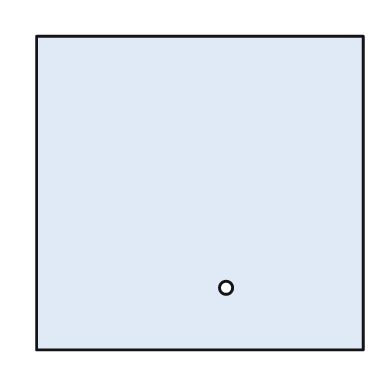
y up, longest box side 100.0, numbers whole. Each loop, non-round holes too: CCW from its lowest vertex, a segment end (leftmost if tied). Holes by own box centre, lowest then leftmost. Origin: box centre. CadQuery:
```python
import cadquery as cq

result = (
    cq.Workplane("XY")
    .moveTo(-50.0, -48.0)
    .lineTo(50.0, -48.0)
    .lineTo(50.0, 48.0)
    .lineTo(-50.0, 48.0)
    .close()
    .moveTo(8.0, -29.0)
    .circle(2.0)
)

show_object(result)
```